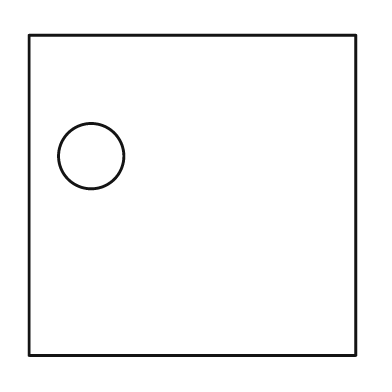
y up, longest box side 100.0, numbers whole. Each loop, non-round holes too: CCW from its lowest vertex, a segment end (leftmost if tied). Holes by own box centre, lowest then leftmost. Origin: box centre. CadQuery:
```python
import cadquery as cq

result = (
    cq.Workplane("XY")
    .moveTo(-50.0, -49.0)
    .lineTo(50.0, -49.0)
    .lineTo(50.0, 49.0)
    .lineTo(-50.0, 49.0)
    .close()
    .moveTo(-31.0, 12.0)
    .circle(10.0)
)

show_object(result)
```